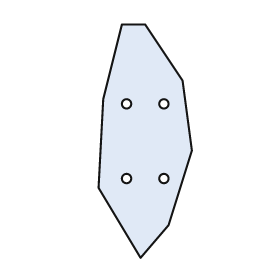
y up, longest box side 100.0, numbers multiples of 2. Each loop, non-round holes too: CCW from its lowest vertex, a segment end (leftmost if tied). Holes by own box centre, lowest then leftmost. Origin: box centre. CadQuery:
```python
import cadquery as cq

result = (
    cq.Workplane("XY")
    .moveTo(-2.0, -50.0)
    .lineTo(10.0, -36.0)
    .lineTo(20.0, -4.0)
    .lineTo(16.0, 26.0)
    .lineTo(0.0, 50.0)
    .lineTo(-10.0, 50.0)
    .lineTo(-18.0, 18.0)
    .lineTo(-20.0, -20.0)
    .close()
    .moveTo(-8.0, -16.0)
    .circle(2.0)
    .moveTo(8.0, -16.0)
    .circle(2.0)
    .moveTo(-8.0, 16.0)
    .circle(2.0)
    .moveTo(8.0, 16.0)
    .circle(2.0)
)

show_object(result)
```